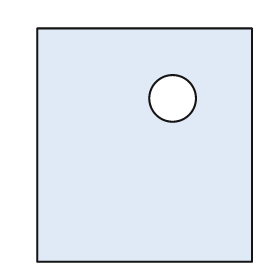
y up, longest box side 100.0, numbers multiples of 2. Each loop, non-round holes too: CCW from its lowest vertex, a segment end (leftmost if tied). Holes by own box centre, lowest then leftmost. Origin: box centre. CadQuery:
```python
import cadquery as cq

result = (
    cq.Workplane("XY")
    .moveTo(-46.0, -50.0)
    .lineTo(46.0, -50.0)
    .lineTo(46.0, 50.0)
    .lineTo(-46.0, 50.0)
    .close()
    .moveTo(12.0, 20.0)
    .circle(10.0)
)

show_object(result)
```